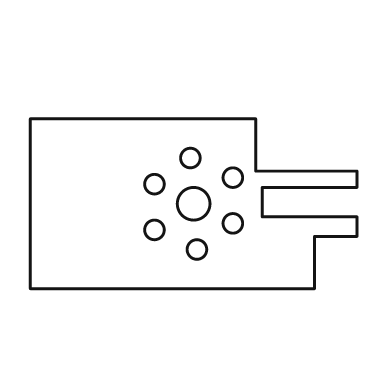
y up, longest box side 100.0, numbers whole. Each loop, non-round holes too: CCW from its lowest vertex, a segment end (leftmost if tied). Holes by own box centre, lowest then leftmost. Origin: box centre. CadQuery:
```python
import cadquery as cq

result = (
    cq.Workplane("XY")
    .moveTo(-50.0, -26.0)
    .lineTo(37.0, -26.0)
    .lineTo(37.0, -10.0)
    .lineTo(50.0, -10.0)
    .lineTo(50.0, -4.0)
    .lineTo(21.0, -4.0)
    .lineTo(21.0, 5.0)
    .lineTo(50.0, 5.0)
    .lineTo(50.0, 10.0)
    .lineTo(19.0, 10.0)
    .lineTo(19.0, 26.0)
    .lineTo(-50.0, 26.0)
    .close()
    .moveTo(1.0, -14.0)
    .circle(3.0)
    .moveTo(-12.0, -8.0)
    .circle(3.0)
    .moveTo(12.0, -6.0)
    .circle(3.0)
    .moveTo(0.0, 0.0)
    .circle(5.0)
    .moveTo(-12.0, 6.0)
    .circle(3.0)
    .moveTo(12.0, 8.0)
    .circle(3.0)
    .moveTo(-1.0, 14.0)
    .circle(3.0)
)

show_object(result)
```